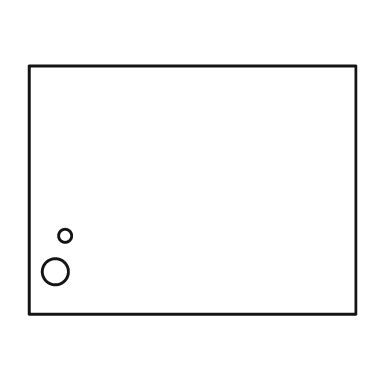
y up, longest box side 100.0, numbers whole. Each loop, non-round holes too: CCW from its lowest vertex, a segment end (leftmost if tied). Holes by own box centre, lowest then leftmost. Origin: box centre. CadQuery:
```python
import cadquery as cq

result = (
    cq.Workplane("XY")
    .moveTo(-50.0, -38.0)
    .lineTo(50.0, -38.0)
    .lineTo(50.0, 38.0)
    .lineTo(-50.0, 38.0)
    .close()
    .moveTo(-42.0, -25.0)
    .circle(4.0)
    .moveTo(-39.0, -14.0)
    .circle(2.0)
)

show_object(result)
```